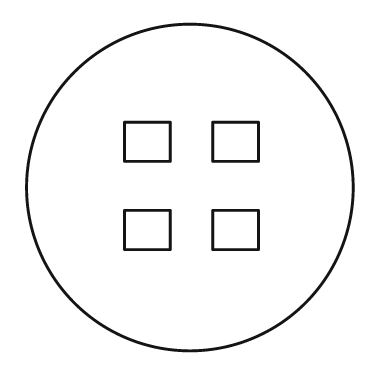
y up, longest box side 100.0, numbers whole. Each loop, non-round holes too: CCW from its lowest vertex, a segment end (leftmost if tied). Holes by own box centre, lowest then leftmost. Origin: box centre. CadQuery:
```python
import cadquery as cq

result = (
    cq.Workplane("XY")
    .moveTo(0.0, 0.0)
    .circle(50.0)
    .moveTo(-20.0, -19.0)
    .lineTo(-6.0, -19.0)
    .lineTo(-6.0, -7.0)
    .lineTo(-20.0, -7.0)
    .close()
    .moveTo(7.0, -19.0)
    .lineTo(21.0, -19.0)
    .lineTo(21.0, -7.0)
    .lineTo(7.0, -7.0)
    .close()
    .moveTo(-20.0, 8.0)
    .lineTo(-6.0, 8.0)
    .lineTo(-6.0, 20.0)
    .lineTo(-20.0, 20.0)
    .close()
    .moveTo(7.0, 8.0)
    .lineTo(21.0, 8.0)
    .lineTo(21.0, 20.0)
    .lineTo(7.0, 20.0)
    .close()
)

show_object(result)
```